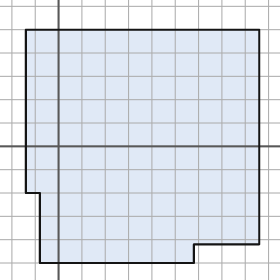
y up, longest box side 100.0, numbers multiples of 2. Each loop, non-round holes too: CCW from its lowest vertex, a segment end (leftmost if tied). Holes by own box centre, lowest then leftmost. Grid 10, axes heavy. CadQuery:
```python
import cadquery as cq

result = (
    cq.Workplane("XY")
    .moveTo(-8.0, -50.0)
    .lineTo(58.0, -50.0)
    .lineTo(58.0, -42.0)
    .lineTo(86.0, -42.0)
    .lineTo(86.0, 50.0)
    .lineTo(-14.0, 50.0)
    .lineTo(-14.0, -20.0)
    .lineTo(-8.0, -20.0)
    .close()
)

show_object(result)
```